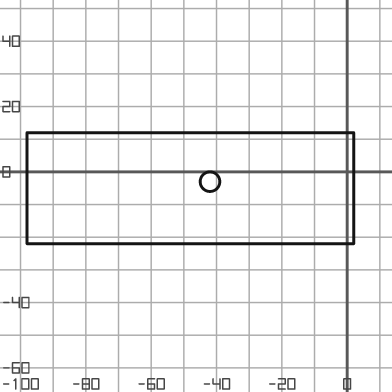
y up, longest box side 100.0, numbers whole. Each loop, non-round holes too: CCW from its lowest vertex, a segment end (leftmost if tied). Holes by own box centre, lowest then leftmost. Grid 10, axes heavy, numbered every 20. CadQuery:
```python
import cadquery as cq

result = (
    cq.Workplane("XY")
    .moveTo(-98.0, -22.0)
    .lineTo(2.0, -22.0)
    .lineTo(2.0, 12.0)
    .lineTo(-98.0, 12.0)
    .close()
    .moveTo(-42.0, -3.0)
    .circle(3.0)
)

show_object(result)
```